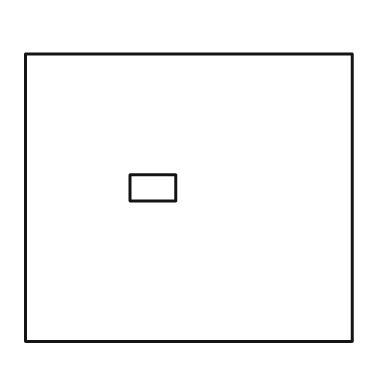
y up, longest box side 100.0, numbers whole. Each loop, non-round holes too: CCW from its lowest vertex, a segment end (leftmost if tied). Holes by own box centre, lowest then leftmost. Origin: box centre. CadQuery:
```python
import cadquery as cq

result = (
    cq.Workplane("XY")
    .moveTo(-50.0, -44.0)
    .lineTo(50.0, -44.0)
    .lineTo(50.0, 44.0)
    .lineTo(-50.0, 44.0)
    .close()
    .moveTo(-18.0, -1.0)
    .lineTo(-4.0, -1.0)
    .lineTo(-4.0, 7.0)
    .lineTo(-18.0, 7.0)
    .close()
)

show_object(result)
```